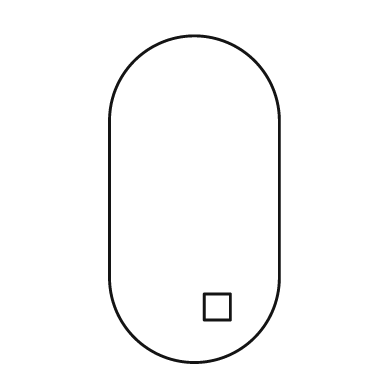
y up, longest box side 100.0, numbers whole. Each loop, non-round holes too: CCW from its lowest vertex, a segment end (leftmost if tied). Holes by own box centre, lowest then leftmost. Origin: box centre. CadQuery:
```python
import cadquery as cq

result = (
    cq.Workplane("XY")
    .moveTo(-26.0, -24.0)
    .threePointArc((0.0, -50.0), (26.0, -24.0))
    .lineTo(26.0, 24.0)
    .threePointArc((0.0, 50.0), (-26.0, 24.0))
    .close()
    .moveTo(3.0, -37.0)
    .lineTo(11.0, -37.0)
    .lineTo(11.0, -29.0)
    .lineTo(3.0, -29.0)
    .close()
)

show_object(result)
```